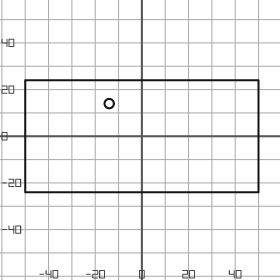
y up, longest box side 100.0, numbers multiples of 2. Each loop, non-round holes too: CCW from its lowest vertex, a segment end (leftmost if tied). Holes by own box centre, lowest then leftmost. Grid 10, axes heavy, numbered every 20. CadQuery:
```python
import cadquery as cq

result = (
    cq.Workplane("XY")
    .moveTo(-50.0, -24.0)
    .lineTo(50.0, -24.0)
    .lineTo(50.0, 24.0)
    .lineTo(-50.0, 24.0)
    .close()
    .moveTo(-14.0, 14.0)
    .circle(2.0)
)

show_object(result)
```